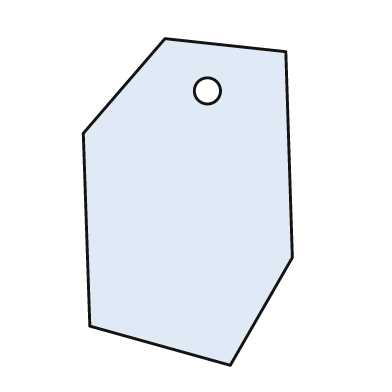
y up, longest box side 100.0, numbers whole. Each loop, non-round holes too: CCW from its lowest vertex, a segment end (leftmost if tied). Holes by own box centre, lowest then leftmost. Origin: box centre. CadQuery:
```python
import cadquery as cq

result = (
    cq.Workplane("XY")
    .moveTo(13.0, -50.0)
    .lineTo(32.0, -17.0)
    .lineTo(30.0, 46.0)
    .lineTo(-7.0, 50.0)
    .lineTo(-32.0, 21.0)
    .lineTo(-30.0, -38.0)
    .close()
    .moveTo(6.0, 34.0)
    .circle(4.0)
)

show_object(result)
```